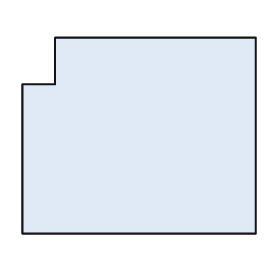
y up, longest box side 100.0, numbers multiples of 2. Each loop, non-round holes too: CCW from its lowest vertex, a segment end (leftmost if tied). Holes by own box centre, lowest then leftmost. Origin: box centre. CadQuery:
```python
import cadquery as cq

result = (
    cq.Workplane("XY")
    .moveTo(-50.0, -42.0)
    .lineTo(50.0, -42.0)
    .lineTo(50.0, 42.0)
    .lineTo(-36.0, 42.0)
    .lineTo(-36.0, 22.0)
    .lineTo(-50.0, 22.0)
    .close()
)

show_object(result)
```